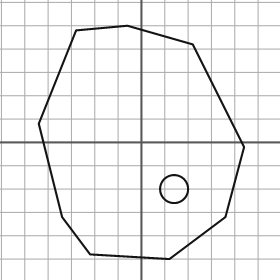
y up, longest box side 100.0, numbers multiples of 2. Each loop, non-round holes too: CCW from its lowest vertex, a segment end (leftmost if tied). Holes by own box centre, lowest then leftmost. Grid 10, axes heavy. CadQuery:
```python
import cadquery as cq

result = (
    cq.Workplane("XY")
    .moveTo(12.0, -50.0)
    .lineTo(36.0, -32.0)
    .lineTo(44.0, -2.0)
    .lineTo(22.0, 42.0)
    .lineTo(-6.0, 50.0)
    .lineTo(-28.0, 48.0)
    .lineTo(-44.0, 8.0)
    .lineTo(-34.0, -32.0)
    .lineTo(-22.0, -48.0)
    .close()
    .moveTo(14.0, -20.0)
    .circle(6.0)
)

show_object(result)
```